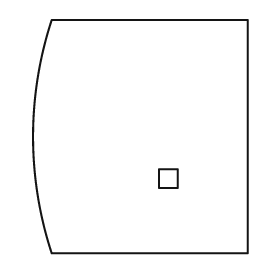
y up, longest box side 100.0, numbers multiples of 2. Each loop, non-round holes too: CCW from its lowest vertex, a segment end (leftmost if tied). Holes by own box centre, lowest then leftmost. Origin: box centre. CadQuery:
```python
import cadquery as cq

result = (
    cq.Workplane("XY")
    .moveTo(-38.0, -50.0)
    .lineTo(46.0, -50.0)
    .lineTo(46.0, 50.0)
    .lineTo(-38.0, 50.0)
    .threePointArc((-46.0, 0.0), (-38.0, -50.0))
    .close()
    .moveTo(8.0, -22.0)
    .lineTo(16.0, -22.0)
    .lineTo(16.0, -14.0)
    .lineTo(8.0, -14.0)
    .close()
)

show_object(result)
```